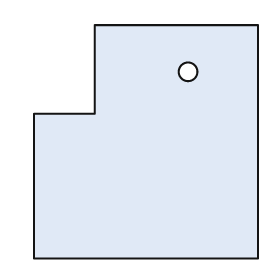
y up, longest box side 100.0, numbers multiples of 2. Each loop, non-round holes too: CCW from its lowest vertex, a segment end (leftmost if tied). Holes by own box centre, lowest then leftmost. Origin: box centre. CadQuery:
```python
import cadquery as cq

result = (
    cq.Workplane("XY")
    .moveTo(-48.0, -50.0)
    .lineTo(48.0, -50.0)
    .lineTo(48.0, 50.0)
    .lineTo(-22.0, 50.0)
    .lineTo(-22.0, 12.0)
    .lineTo(-48.0, 12.0)
    .close()
    .moveTo(18.0, 30.0)
    .circle(4.0)
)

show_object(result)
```